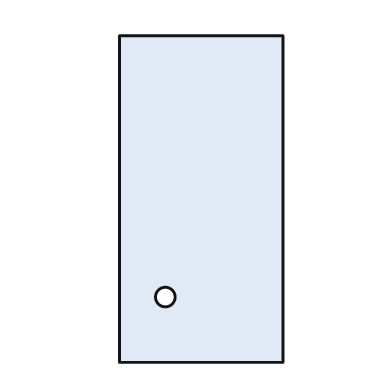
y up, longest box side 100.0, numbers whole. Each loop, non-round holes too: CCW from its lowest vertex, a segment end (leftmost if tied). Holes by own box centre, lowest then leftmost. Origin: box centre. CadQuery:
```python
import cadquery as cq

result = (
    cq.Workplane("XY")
    .moveTo(-25.0, -50.0)
    .lineTo(25.0, -50.0)
    .lineTo(25.0, 50.0)
    .lineTo(-25.0, 50.0)
    .close()
    .moveTo(-11.0, -30.0)
    .circle(3.0)
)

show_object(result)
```